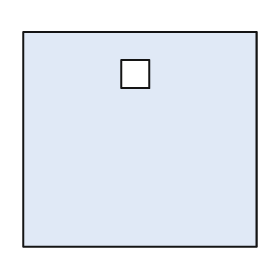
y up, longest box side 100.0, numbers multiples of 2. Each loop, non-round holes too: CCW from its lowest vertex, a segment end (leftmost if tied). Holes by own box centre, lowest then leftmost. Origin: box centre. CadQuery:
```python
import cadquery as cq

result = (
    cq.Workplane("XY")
    .moveTo(-50.0, -46.0)
    .lineTo(50.0, -46.0)
    .lineTo(50.0, 46.0)
    .lineTo(-50.0, 46.0)
    .close()
    .moveTo(-8.0, 22.0)
    .lineTo(4.0, 22.0)
    .lineTo(4.0, 34.0)
    .lineTo(-8.0, 34.0)
    .close()
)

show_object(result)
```